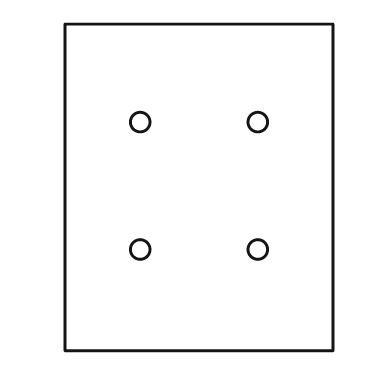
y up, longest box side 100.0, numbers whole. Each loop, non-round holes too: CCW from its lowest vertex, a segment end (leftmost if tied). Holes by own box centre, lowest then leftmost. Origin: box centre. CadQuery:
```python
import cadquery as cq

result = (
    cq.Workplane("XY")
    .moveTo(-41.0, -50.0)
    .lineTo(41.0, -50.0)
    .lineTo(41.0, 50.0)
    .lineTo(-41.0, 50.0)
    .close()
    .moveTo(-18.0, -19.0)
    .circle(3.0)
    .moveTo(18.0, -19.0)
    .circle(3.0)
    .moveTo(-18.0, 20.0)
    .circle(3.0)
    .moveTo(18.0, 20.0)
    .circle(3.0)
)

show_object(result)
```